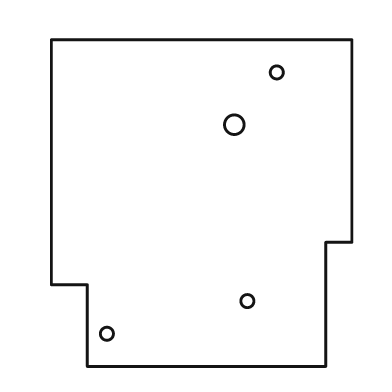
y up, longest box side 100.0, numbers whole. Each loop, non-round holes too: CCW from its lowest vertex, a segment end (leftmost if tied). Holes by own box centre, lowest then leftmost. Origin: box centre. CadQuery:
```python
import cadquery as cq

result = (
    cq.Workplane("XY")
    .moveTo(-35.0, -50.0)
    .lineTo(38.0, -50.0)
    .lineTo(38.0, -12.0)
    .lineTo(46.0, -12.0)
    .lineTo(46.0, 50.0)
    .lineTo(-46.0, 50.0)
    .lineTo(-46.0, -25.0)
    .lineTo(-35.0, -25.0)
    .close()
    .moveTo(-29.0, -40.0)
    .circle(2.0)
    .moveTo(14.0, -30.0)
    .circle(2.0)
    .moveTo(10.0, 24.0)
    .circle(3.0)
    .moveTo(23.0, 40.0)
    .circle(2.0)
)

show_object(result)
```